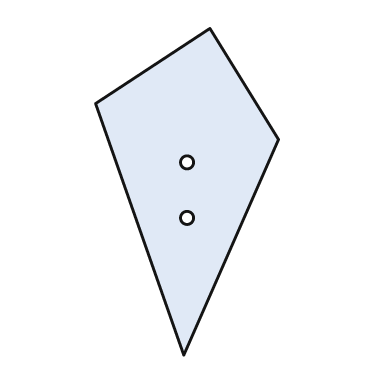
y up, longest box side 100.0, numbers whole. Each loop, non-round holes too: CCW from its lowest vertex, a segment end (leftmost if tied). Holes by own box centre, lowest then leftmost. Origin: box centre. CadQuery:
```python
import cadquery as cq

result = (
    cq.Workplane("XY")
    .moveTo(-1.0, -50.0)
    .lineTo(28.0, 16.0)
    .lineTo(7.0, 50.0)
    .lineTo(-28.0, 27.0)
    .close()
    .moveTo(0.0, -8.0)
    .circle(2.0)
    .moveTo(0.0, 9.0)
    .circle(2.0)
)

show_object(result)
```